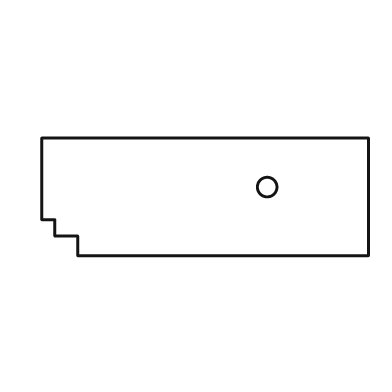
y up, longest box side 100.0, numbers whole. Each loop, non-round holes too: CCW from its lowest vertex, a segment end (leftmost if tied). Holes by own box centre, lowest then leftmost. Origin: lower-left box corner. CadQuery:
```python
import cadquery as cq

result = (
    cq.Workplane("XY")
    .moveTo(11.0, 0.0)
    .lineTo(100.0, 0.0)
    .lineTo(100.0, 36.0)
    .lineTo(0.0, 36.0)
    .lineTo(0.0, 11.0)
    .lineTo(4.0, 11.0)
    .lineTo(4.0, 6.0)
    .lineTo(11.0, 6.0)
    .close()
    .moveTo(69.0, 21.0)
    .circle(3.0)
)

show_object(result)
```